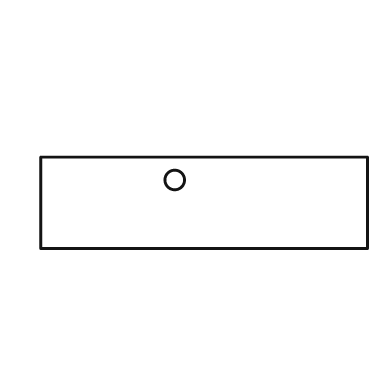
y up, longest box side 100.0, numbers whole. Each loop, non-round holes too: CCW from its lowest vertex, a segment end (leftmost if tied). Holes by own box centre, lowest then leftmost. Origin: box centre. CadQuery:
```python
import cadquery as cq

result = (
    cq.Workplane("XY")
    .moveTo(-50.0, -14.0)
    .lineTo(50.0, -14.0)
    .lineTo(50.0, 14.0)
    .lineTo(-50.0, 14.0)
    .close()
    .moveTo(-9.0, 7.0)
    .circle(3.0)
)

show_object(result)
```